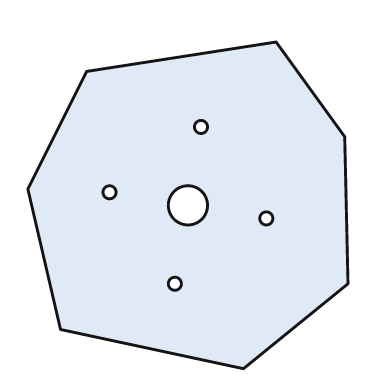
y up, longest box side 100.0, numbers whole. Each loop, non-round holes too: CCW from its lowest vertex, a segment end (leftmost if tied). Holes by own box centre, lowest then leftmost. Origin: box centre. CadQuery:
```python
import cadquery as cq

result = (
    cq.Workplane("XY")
    .moveTo(17.0, -50.0)
    .lineTo(49.0, -24.0)
    .lineTo(48.0, 21.0)
    .lineTo(27.0, 50.0)
    .lineTo(-31.0, 41.0)
    .lineTo(-49.0, 5.0)
    .lineTo(-39.0, -38.0)
    .close()
    .moveTo(-4.0, -24.0)
    .circle(2.0)
    .moveTo(24.0, -4.0)
    .circle(2.0)
    .moveTo(0.0, 0.0)
    .circle(6.0)
    .moveTo(-24.0, 4.0)
    .circle(2.0)
    .moveTo(4.0, 24.0)
    .circle(2.0)
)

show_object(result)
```